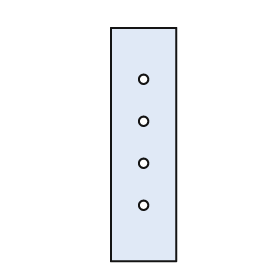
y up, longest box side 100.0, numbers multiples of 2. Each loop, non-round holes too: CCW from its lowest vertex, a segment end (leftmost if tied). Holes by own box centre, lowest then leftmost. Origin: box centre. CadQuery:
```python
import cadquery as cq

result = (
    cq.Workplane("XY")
    .moveTo(-14.0, -50.0)
    .lineTo(14.0, -50.0)
    .lineTo(14.0, 50.0)
    .lineTo(-14.0, 50.0)
    .close()
    .moveTo(0.0, -26.0)
    .circle(2.0)
    .moveTo(0.0, -8.0)
    .circle(2.0)
    .moveTo(0.0, 10.0)
    .circle(2.0)
    .moveTo(0.0, 28.0)
    .circle(2.0)
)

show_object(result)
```